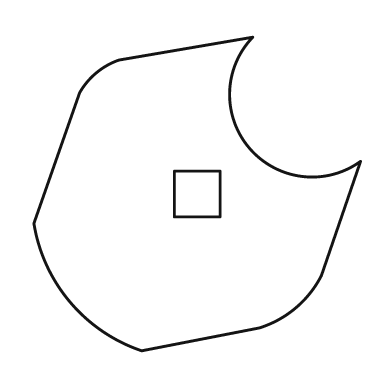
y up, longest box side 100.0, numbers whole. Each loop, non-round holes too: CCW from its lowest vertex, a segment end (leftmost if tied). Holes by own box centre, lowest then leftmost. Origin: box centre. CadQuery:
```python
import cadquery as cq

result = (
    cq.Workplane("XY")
    .moveTo(-17.0, -48.0)
    .lineTo(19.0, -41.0)
    .threePointArc((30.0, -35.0), (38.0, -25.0))
    .lineTo(50.0, 10.0)
    .threePointArc((16.0, 14.0), (17.0, 48.0))
    .lineTo(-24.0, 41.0)
    .threePointArc((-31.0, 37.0), (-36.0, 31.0))
    .lineTo(-50.0, -9.0)
    .threePointArc((-39.0, -33.0), (-17.0, -48.0))
    .close()
    .moveTo(-7.0, -7.0)
    .lineTo(7.0, -7.0)
    .lineTo(7.0, 7.0)
    .lineTo(-7.0, 7.0)
    .close()
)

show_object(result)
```